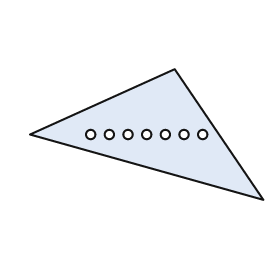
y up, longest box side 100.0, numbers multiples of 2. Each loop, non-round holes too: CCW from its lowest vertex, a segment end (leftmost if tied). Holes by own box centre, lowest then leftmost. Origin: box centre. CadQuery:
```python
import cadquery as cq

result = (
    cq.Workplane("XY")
    .moveTo(50.0, -28.0)
    .lineTo(12.0, 28.0)
    .lineTo(-50.0, 0.0)
    .close()
    .moveTo(-24.0, 0.0)
    .circle(2.0)
    .moveTo(-16.0, 0.0)
    .circle(2.0)
    .moveTo(-8.0, 0.0)
    .circle(2.0)
    .moveTo(0.0, 0.0)
    .circle(2.0)
    .moveTo(8.0, 0.0)
    .circle(2.0)
    .moveTo(16.0, 0.0)
    .circle(2.0)
    .moveTo(24.0, 0.0)
    .circle(2.0)
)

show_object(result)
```